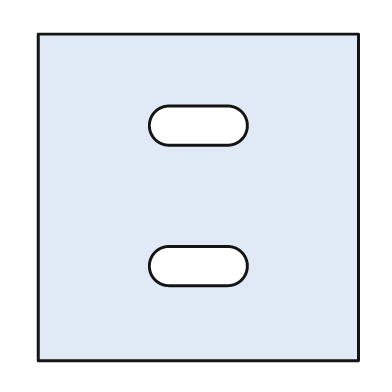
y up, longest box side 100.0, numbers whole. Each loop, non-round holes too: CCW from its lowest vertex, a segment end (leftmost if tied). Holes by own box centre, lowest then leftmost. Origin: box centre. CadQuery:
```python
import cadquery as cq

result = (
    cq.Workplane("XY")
    .moveTo(-49.0, -50.0)
    .lineTo(49.0, -50.0)
    .lineTo(49.0, 50.0)
    .lineTo(-49.0, 50.0)
    .close()
    .moveTo(-9.0, -27.0)
    .lineTo(9.0, -27.0)
    .threePointArc((15.0, -21.0), (9.0, -15.0))
    .lineTo(-9.0, -15.0)
    .threePointArc((-15.0, -21.0), (-9.0, -27.0))
    .close()
    .moveTo(-9.0, 16.0)
    .lineTo(9.0, 16.0)
    .threePointArc((15.0, 22.0), (9.0, 28.0))
    .lineTo(-9.0, 28.0)
    .threePointArc((-15.0, 22.0), (-9.0, 16.0))
    .close()
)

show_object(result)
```